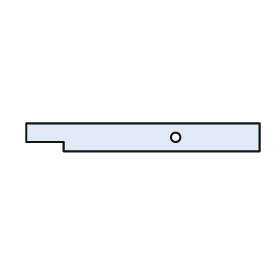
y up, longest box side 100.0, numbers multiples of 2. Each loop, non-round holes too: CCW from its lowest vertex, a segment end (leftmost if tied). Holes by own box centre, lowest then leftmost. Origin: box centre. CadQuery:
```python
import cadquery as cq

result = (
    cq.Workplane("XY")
    .moveTo(-34.0, -6.0)
    .lineTo(50.0, -6.0)
    .lineTo(50.0, 6.0)
    .lineTo(-50.0, 6.0)
    .lineTo(-50.0, -2.0)
    .lineTo(-34.0, -2.0)
    .close()
    .moveTo(14.0, 0.0)
    .circle(2.0)
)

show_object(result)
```